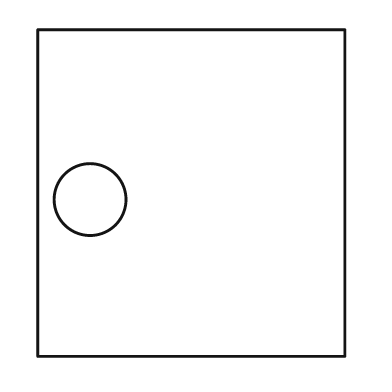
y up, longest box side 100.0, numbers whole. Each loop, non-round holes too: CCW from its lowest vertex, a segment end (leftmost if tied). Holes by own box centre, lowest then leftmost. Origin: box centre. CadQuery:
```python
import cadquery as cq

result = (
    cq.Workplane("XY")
    .moveTo(-47.0, -50.0)
    .lineTo(47.0, -50.0)
    .lineTo(47.0, 50.0)
    .lineTo(-47.0, 50.0)
    .close()
    .moveTo(-31.0, -2.0)
    .circle(11.0)
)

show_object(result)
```